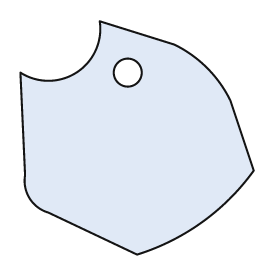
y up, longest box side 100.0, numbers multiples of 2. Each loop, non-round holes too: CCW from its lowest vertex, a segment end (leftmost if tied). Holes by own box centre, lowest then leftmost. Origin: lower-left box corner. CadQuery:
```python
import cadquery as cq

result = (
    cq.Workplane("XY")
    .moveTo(50.0, 0.0)
    .threePointArc((78.0, 14.0), (100.0, 36.0))
    .lineTo(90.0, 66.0)
    .threePointArc((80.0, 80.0), (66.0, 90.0))
    .lineTo(34.0, 100.0)
    .threePointArc((24.0, 78.0), (0.0, 78.0))
    .lineTo(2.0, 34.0)
    .threePointArc((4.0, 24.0), (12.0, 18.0))
    .close()
    .moveTo(46.0, 78.0)
    .circle(6.0)
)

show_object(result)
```